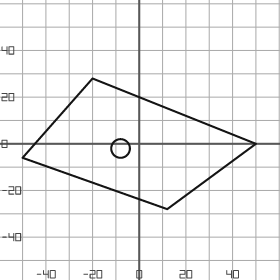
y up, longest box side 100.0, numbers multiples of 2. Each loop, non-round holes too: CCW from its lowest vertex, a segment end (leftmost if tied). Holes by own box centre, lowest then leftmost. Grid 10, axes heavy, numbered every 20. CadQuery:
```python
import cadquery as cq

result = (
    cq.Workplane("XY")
    .moveTo(12.0, -28.0)
    .lineTo(50.0, 0.0)
    .lineTo(-20.0, 28.0)
    .lineTo(-50.0, -6.0)
    .close()
    .moveTo(-8.0, -2.0)
    .circle(4.0)
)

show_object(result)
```